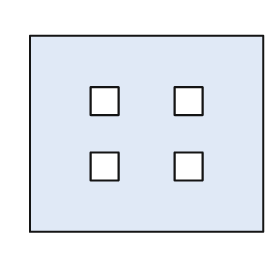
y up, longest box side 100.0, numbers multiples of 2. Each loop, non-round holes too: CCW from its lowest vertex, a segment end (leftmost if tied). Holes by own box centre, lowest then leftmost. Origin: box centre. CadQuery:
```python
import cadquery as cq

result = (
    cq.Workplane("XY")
    .moveTo(-50.0, -42.0)
    .lineTo(50.0, -42.0)
    .lineTo(50.0, 42.0)
    .lineTo(-50.0, 42.0)
    .close()
    .moveTo(-24.0, -20.0)
    .lineTo(-12.0, -20.0)
    .lineTo(-12.0, -8.0)
    .lineTo(-24.0, -8.0)
    .close()
    .moveTo(12.0, -20.0)
    .lineTo(24.0, -20.0)
    .lineTo(24.0, -8.0)
    .lineTo(12.0, -8.0)
    .close()
    .moveTo(-24.0, 8.0)
    .lineTo(-12.0, 8.0)
    .lineTo(-12.0, 20.0)
    .lineTo(-24.0, 20.0)
    .close()
    .moveTo(12.0, 8.0)
    .lineTo(24.0, 8.0)
    .lineTo(24.0, 20.0)
    .lineTo(12.0, 20.0)
    .close()
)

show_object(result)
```